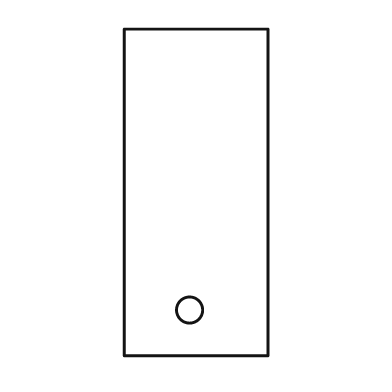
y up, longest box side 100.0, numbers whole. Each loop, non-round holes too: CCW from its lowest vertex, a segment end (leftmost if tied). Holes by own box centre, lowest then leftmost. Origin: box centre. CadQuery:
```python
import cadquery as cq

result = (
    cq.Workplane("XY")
    .moveTo(-22.0, -50.0)
    .lineTo(22.0, -50.0)
    .lineTo(22.0, 50.0)
    .lineTo(-22.0, 50.0)
    .close()
    .moveTo(-2.0, -36.0)
    .circle(4.0)
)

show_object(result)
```